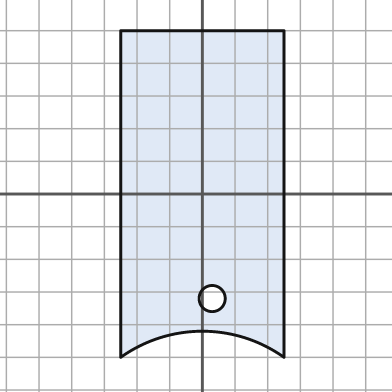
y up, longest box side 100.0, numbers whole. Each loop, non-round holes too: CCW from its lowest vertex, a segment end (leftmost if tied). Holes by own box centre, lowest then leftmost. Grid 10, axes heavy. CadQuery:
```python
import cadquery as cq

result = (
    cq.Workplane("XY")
    .moveTo(-25.0, -50.0)
    .threePointArc((0.0, -42.0), (25.0, -50.0))
    .lineTo(25.0, 50.0)
    .lineTo(-25.0, 50.0)
    .close()
    .moveTo(3.0, -32.0)
    .circle(4.0)
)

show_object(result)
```